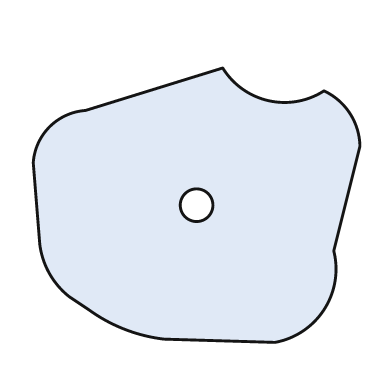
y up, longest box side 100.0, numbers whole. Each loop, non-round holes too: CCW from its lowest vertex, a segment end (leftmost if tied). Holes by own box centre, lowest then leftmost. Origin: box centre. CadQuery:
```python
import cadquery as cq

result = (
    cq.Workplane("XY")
    .moveTo(24.0, -42.0)
    .threePointArc((39.0, -32.0), (42.0, -14.0))
    .lineTo(50.0, 18.0)
    .threePointArc((47.0, 28.0), (39.0, 35.0))
    .threePointArc((22.0, 32.0), (8.0, 42.0))
    .lineTo(-34.0, 29.0)
    .threePointArc((-45.0, 24.0), (-50.0, 13.0))
    .lineTo(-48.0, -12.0)
    .threePointArc((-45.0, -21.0), (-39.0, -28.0))
    .lineTo(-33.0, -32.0)
    .threePointArc((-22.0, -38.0), (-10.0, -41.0))
    .close()
    .moveTo(0.0, 0.0)
    .circle(5.0)
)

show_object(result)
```